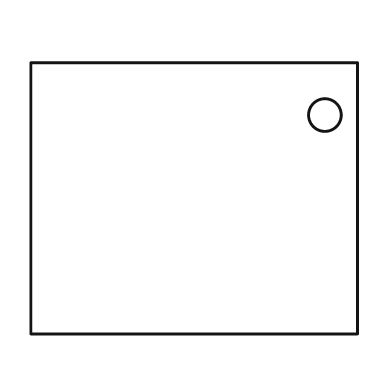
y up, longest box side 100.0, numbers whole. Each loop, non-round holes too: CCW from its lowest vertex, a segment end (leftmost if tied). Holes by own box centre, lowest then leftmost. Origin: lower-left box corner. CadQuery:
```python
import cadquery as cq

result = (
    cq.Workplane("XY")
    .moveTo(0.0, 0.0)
    .lineTo(100.0, 0.0)
    .lineTo(100.0, 83.0)
    .lineTo(0.0, 83.0)
    .close()
    .moveTo(90.0, 67.0)
    .circle(5.0)
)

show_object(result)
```